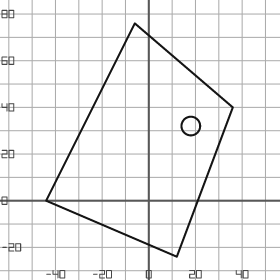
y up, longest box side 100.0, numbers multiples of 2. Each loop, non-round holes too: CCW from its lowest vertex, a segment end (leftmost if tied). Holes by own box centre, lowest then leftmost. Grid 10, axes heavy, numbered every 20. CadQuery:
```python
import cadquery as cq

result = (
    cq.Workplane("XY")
    .moveTo(12.0, -24.0)
    .lineTo(36.0, 40.0)
    .lineTo(-6.0, 76.0)
    .lineTo(-44.0, 0.0)
    .close()
    .moveTo(18.0, 32.0)
    .circle(4.0)
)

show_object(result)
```